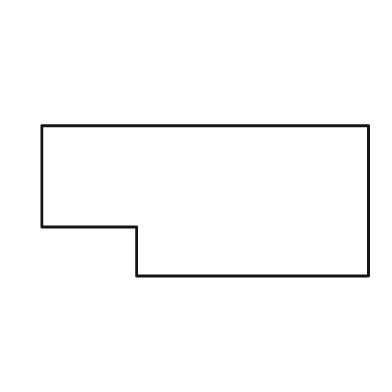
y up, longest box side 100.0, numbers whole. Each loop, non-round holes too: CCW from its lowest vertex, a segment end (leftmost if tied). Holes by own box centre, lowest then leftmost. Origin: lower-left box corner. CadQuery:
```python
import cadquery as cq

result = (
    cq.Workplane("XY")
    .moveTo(29.0, 0.0)
    .lineTo(100.0, 0.0)
    .lineTo(100.0, 46.0)
    .lineTo(0.0, 46.0)
    .lineTo(0.0, 15.0)
    .lineTo(29.0, 15.0)
    .close()
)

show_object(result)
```